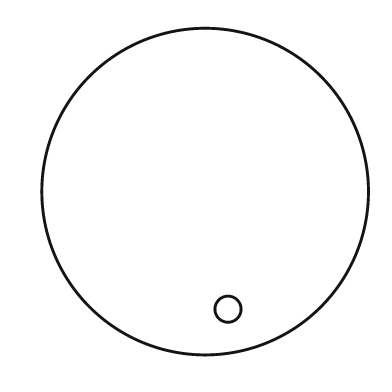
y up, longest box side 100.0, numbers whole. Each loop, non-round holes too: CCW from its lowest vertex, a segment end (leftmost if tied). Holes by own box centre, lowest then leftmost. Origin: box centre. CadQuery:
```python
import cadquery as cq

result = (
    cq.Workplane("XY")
    .moveTo(0.0, 0.0)
    .circle(50.0)
    .moveTo(7.0, -36.0)
    .circle(4.0)
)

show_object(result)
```